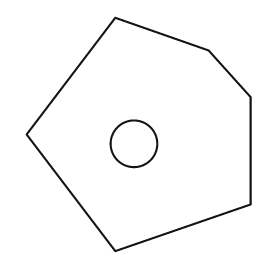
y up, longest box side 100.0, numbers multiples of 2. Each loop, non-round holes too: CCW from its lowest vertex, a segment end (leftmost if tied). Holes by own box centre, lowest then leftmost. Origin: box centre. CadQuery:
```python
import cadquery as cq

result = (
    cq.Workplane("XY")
    .moveTo(-10.0, -50.0)
    .lineTo(48.0, -30.0)
    .lineTo(48.0, 16.0)
    .lineTo(30.0, 36.0)
    .lineTo(-10.0, 50.0)
    .lineTo(-48.0, 0.0)
    .close()
    .moveTo(-2.0, -4.0)
    .circle(10.0)
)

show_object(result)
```